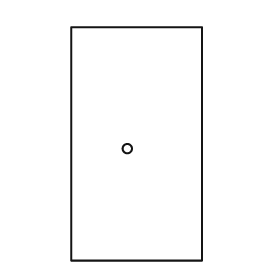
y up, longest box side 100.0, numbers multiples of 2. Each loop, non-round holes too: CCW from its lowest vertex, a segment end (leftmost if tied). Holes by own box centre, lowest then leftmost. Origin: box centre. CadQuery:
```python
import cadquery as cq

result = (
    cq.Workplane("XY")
    .moveTo(-28.0, -50.0)
    .lineTo(28.0, -50.0)
    .lineTo(28.0, 50.0)
    .lineTo(-28.0, 50.0)
    .close()
    .moveTo(-4.0, -2.0)
    .circle(2.0)
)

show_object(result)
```